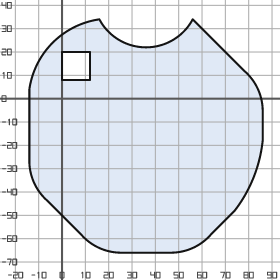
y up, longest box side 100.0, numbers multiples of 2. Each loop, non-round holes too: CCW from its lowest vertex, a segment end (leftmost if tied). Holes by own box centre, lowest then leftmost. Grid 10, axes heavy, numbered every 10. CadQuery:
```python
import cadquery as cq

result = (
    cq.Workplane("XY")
    .moveTo(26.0, -66.0)
    .lineTo(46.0, -66.0)
    .threePointArc((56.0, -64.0), (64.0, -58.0))
    .lineTo(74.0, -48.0)
    .threePointArc((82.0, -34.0), (86.0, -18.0))
    .lineTo(86.0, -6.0)
    .threePointArc((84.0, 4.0), (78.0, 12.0))
    .lineTo(56.0, 34.0)
    .threePointArc((36.0, 22.0), (16.0, 34.0))
    .threePointArc((-4.0, 24.0), (-14.0, 4.0))
    .lineTo(-14.0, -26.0)
    .threePointArc((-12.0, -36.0), (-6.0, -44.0))
    .lineTo(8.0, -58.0)
    .threePointArc((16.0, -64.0), (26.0, -66.0))
    .close()
    .moveTo(0.0, 8.0)
    .lineTo(12.0, 8.0)
    .lineTo(12.0, 20.0)
    .lineTo(0.0, 20.0)
    .close()
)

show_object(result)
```